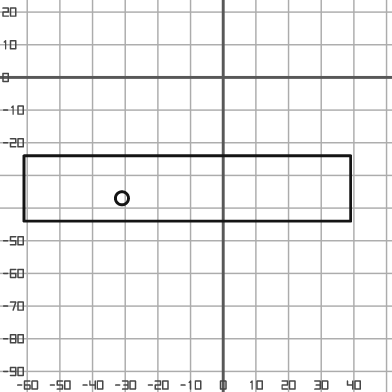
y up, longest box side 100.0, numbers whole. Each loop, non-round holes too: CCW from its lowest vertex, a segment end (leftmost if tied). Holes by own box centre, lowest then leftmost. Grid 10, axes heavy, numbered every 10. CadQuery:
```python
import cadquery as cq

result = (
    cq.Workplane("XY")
    .moveTo(-61.0, -44.0)
    .lineTo(39.0, -44.0)
    .lineTo(39.0, -24.0)
    .lineTo(-61.0, -24.0)
    .close()
    .moveTo(-31.0, -37.0)
    .circle(2.0)
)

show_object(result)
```